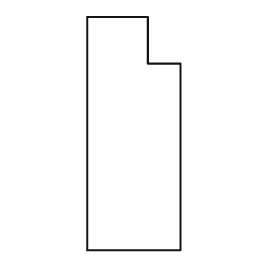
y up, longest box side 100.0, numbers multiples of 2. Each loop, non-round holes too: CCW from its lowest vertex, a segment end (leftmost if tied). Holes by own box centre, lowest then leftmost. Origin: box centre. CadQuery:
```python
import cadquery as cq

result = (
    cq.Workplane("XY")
    .moveTo(-20.0, -50.0)
    .lineTo(20.0, -50.0)
    .lineTo(20.0, 30.0)
    .lineTo(6.0, 30.0)
    .lineTo(6.0, 50.0)
    .lineTo(-20.0, 50.0)
    .close()
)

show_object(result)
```